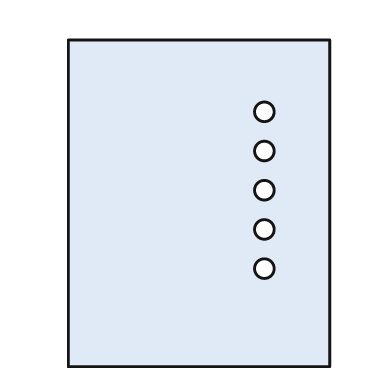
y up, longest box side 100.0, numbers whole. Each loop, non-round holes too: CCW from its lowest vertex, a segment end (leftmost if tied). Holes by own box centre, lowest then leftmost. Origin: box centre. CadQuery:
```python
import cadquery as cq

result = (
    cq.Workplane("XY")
    .moveTo(-40.0, -50.0)
    .lineTo(40.0, -50.0)
    .lineTo(40.0, 50.0)
    .lineTo(-40.0, 50.0)
    .close()
    .moveTo(20.0, -20.0)
    .circle(3.0)
    .moveTo(20.0, -8.0)
    .circle(3.0)
    .moveTo(20.0, 4.0)
    .circle(3.0)
    .moveTo(20.0, 16.0)
    .circle(3.0)
    .moveTo(20.0, 28.0)
    .circle(3.0)
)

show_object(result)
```